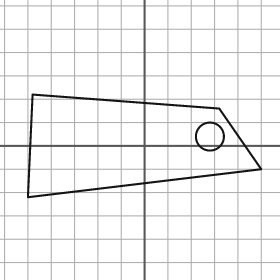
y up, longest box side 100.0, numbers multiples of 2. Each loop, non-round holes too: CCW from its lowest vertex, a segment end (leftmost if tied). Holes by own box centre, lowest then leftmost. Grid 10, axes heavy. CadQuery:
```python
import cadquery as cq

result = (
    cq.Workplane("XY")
    .moveTo(-50.0, -22.0)
    .lineTo(50.0, -10.0)
    .lineTo(32.0, 16.0)
    .lineTo(-48.0, 22.0)
    .close()
    .moveTo(28.0, 4.0)
    .circle(6.0)
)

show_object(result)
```